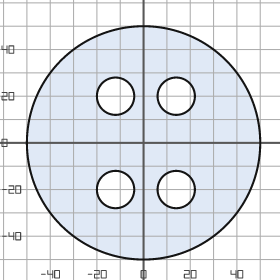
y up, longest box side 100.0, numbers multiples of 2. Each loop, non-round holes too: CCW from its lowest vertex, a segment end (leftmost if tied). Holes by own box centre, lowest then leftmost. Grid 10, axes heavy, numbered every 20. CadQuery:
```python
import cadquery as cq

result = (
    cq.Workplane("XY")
    .moveTo(0.0, 0.0)
    .circle(50.0)
    .moveTo(-12.0, -20.0)
    .circle(8.0)
    .moveTo(14.0, -20.0)
    .circle(8.0)
    .moveTo(-12.0, 20.0)
    .circle(8.0)
    .moveTo(14.0, 20.0)
    .circle(8.0)
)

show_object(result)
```